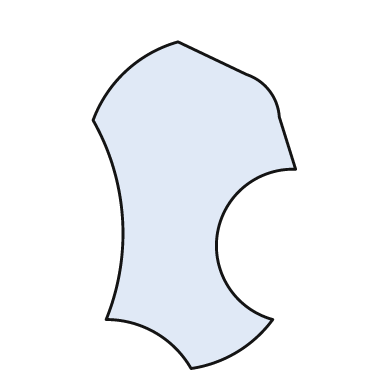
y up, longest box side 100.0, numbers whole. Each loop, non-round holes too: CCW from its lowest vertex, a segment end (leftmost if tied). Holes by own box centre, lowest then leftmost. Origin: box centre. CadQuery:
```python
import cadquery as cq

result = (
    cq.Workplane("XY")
    .moveTo(-1.0, -50.0)
    .threePointArc((13.0, -45.0), (24.0, -35.0))
    .threePointArc((7.0, -9.0), (31.0, 11.0))
    .lineTo(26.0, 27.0)
    .threePointArc((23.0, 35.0), (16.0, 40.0))
    .lineTo(-5.0, 50.0)
    .threePointArc((-21.0, 41.0), (-31.0, 26.0))
    .threePointArc((-22.0, -4.0), (-27.0, -35.0))
    .threePointArc((-12.0, -39.0), (-1.0, -50.0))
    .close()
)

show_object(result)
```